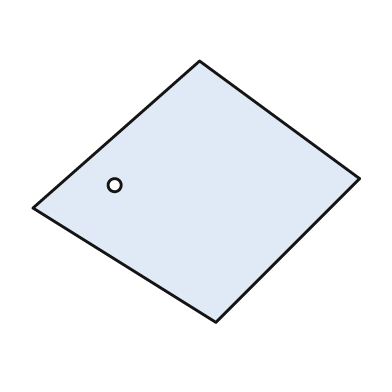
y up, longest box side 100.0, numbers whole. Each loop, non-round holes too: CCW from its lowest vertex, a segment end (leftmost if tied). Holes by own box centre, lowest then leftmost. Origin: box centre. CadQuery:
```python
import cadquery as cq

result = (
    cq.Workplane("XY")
    .moveTo(6.0, -40.0)
    .lineTo(50.0, 4.0)
    .lineTo(1.0, 40.0)
    .lineTo(-50.0, -5.0)
    .close()
    .moveTo(-25.0, 2.0)
    .circle(2.0)
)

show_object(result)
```